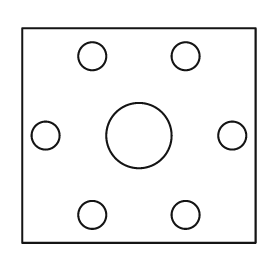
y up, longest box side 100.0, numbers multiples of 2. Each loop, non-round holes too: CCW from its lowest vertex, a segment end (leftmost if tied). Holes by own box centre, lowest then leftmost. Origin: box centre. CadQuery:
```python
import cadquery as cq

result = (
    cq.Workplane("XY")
    .moveTo(-50.0, -46.0)
    .lineTo(50.0, -46.0)
    .lineTo(50.0, 46.0)
    .lineTo(-50.0, 46.0)
    .close()
    .moveTo(-20.0, -34.0)
    .circle(6.0)
    .moveTo(20.0, -34.0)
    .circle(6.0)
    .moveTo(-40.0, 0.0)
    .circle(6.0)
    .moveTo(0.0, 0.0)
    .circle(14.0)
    .moveTo(40.0, 0.0)
    .circle(6.0)
    .moveTo(-20.0, 34.0)
    .circle(6.0)
    .moveTo(20.0, 34.0)
    .circle(6.0)
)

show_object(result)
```